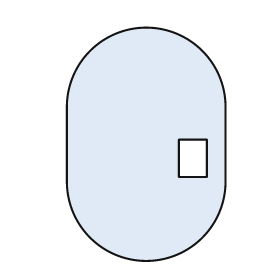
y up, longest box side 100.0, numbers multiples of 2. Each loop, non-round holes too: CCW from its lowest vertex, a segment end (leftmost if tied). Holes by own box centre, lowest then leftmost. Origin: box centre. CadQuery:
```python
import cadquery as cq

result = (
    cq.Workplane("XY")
    .moveTo(-34.0, -16.0)
    .threePointArc((0.0, -50.0), (34.0, -16.0))
    .lineTo(34.0, 16.0)
    .threePointArc((0.0, 50.0), (-34.0, 16.0))
    .close()
    .moveTo(14.0, -14.0)
    .lineTo(26.0, -14.0)
    .lineTo(26.0, 2.0)
    .lineTo(14.0, 2.0)
    .close()
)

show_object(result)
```